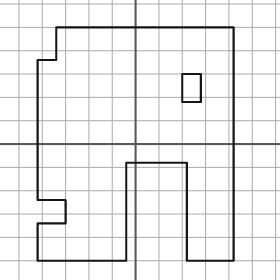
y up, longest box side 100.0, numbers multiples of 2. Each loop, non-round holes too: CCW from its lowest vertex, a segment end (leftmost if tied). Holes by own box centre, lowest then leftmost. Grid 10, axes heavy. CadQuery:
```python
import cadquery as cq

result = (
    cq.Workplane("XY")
    .moveTo(-42.0, -50.0)
    .lineTo(-4.0, -50.0)
    .lineTo(-4.0, -8.0)
    .lineTo(22.0, -8.0)
    .lineTo(22.0, -50.0)
    .lineTo(42.0, -50.0)
    .lineTo(42.0, 50.0)
    .lineTo(-34.0, 50.0)
    .lineTo(-34.0, 36.0)
    .lineTo(-42.0, 36.0)
    .lineTo(-42.0, -24.0)
    .lineTo(-30.0, -24.0)
    .lineTo(-30.0, -34.0)
    .lineTo(-42.0, -34.0)
    .close()
    .moveTo(20.0, 18.0)
    .lineTo(28.0, 18.0)
    .lineTo(28.0, 30.0)
    .lineTo(20.0, 30.0)
    .close()
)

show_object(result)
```